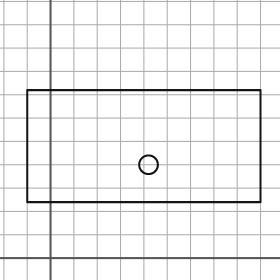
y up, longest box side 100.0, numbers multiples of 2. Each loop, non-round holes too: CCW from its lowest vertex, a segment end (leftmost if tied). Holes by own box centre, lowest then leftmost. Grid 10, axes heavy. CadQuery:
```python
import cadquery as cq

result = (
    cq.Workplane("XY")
    .moveTo(-10.0, 24.0)
    .lineTo(90.0, 24.0)
    .lineTo(90.0, 72.0)
    .lineTo(-10.0, 72.0)
    .close()
    .moveTo(42.0, 40.0)
    .circle(4.0)
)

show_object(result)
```